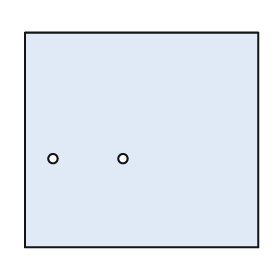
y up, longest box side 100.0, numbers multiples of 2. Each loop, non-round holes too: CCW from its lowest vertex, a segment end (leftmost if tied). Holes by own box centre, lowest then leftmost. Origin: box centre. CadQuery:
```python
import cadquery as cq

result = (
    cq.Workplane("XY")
    .moveTo(-50.0, -46.0)
    .lineTo(50.0, -46.0)
    .lineTo(50.0, 46.0)
    .lineTo(-50.0, 46.0)
    .close()
    .moveTo(-38.0, -8.0)
    .circle(2.0)
    .moveTo(-8.0, -8.0)
    .circle(2.0)
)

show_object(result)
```